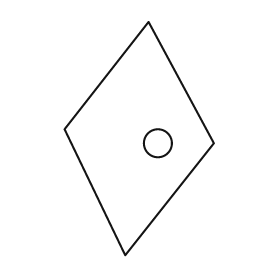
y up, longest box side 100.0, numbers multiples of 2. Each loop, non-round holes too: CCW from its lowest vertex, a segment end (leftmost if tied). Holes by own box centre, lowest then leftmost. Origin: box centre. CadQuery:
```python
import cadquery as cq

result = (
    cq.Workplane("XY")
    .moveTo(-6.0, -50.0)
    .lineTo(32.0, -2.0)
    .lineTo(4.0, 50.0)
    .lineTo(-32.0, 4.0)
    .close()
    .moveTo(8.0, -2.0)
    .circle(6.0)
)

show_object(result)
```